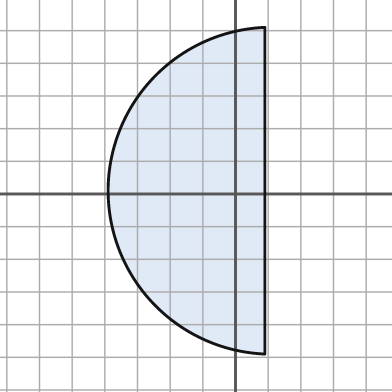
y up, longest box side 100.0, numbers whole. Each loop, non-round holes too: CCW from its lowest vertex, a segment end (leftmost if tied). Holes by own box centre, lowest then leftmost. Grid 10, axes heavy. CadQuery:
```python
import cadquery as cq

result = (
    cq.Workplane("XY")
    .moveTo(9.0, -49.0)
    .lineTo(9.0, 51.0)
    .threePointArc((-39.0, 1.0), (9.0, -49.0))
    .close()
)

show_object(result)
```